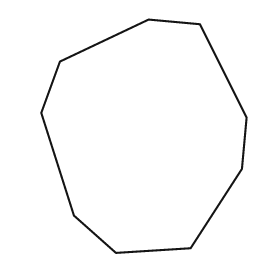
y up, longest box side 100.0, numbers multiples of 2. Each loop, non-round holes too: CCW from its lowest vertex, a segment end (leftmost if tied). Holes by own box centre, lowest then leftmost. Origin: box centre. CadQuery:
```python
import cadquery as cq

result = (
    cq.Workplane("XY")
    .moveTo(-12.0, -50.0)
    .lineTo(20.0, -48.0)
    .lineTo(42.0, -14.0)
    .lineTo(44.0, 8.0)
    .lineTo(24.0, 48.0)
    .lineTo(2.0, 50.0)
    .lineTo(-36.0, 32.0)
    .lineTo(-44.0, 10.0)
    .lineTo(-30.0, -34.0)
    .close()
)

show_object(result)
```